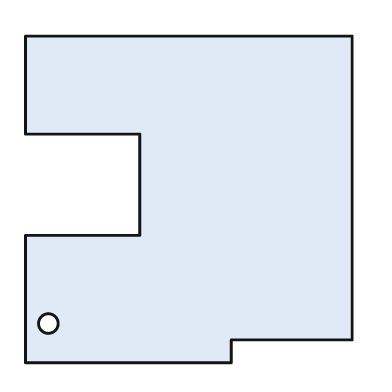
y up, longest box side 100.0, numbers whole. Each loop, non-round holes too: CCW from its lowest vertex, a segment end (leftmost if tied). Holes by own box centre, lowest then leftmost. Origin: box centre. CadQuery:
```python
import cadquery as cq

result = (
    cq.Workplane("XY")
    .moveTo(-50.0, -50.0)
    .lineTo(13.0, -50.0)
    .lineTo(13.0, -43.0)
    .lineTo(50.0, -43.0)
    .lineTo(50.0, 50.0)
    .lineTo(-50.0, 50.0)
    .lineTo(-50.0, 20.0)
    .lineTo(-15.0, 20.0)
    .lineTo(-15.0, -11.0)
    .lineTo(-50.0, -11.0)
    .close()
    .moveTo(-43.0, -38.0)
    .circle(3.0)
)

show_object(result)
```